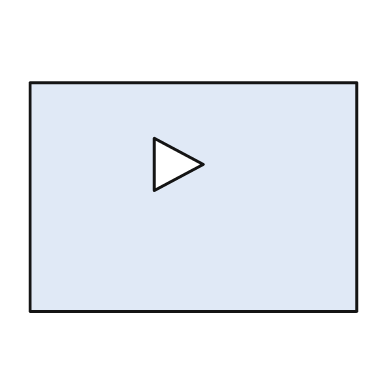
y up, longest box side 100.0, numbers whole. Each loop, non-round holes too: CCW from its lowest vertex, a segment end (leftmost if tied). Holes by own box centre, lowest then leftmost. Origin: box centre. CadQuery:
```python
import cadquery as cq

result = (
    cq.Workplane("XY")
    .moveTo(-50.0, -35.0)
    .lineTo(50.0, -35.0)
    .lineTo(50.0, 35.0)
    .lineTo(-50.0, 35.0)
    .close()
    .moveTo(-12.0, 2.0)
    .lineTo(3.0, 10.0)
    .lineTo(-12.0, 18.0)
    .close()
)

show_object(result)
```